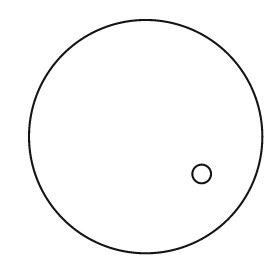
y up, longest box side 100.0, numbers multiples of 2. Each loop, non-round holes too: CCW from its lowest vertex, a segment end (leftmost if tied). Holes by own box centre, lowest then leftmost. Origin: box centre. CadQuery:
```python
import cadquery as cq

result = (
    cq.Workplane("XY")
    .moveTo(0.0, 0.0)
    .circle(50.0)
    .moveTo(24.0, -16.0)
    .circle(4.0)
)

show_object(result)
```